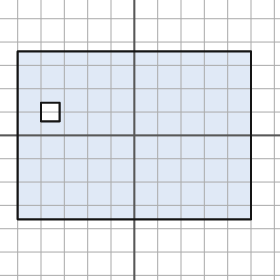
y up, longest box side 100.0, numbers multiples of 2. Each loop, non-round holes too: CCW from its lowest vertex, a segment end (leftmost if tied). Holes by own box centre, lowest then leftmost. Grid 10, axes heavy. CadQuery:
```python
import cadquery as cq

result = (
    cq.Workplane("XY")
    .moveTo(-50.0, -36.0)
    .lineTo(50.0, -36.0)
    .lineTo(50.0, 36.0)
    .lineTo(-50.0, 36.0)
    .close()
    .moveTo(-40.0, 6.0)
    .lineTo(-32.0, 6.0)
    .lineTo(-32.0, 14.0)
    .lineTo(-40.0, 14.0)
    .close()
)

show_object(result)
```